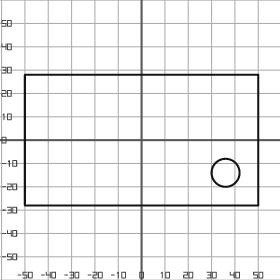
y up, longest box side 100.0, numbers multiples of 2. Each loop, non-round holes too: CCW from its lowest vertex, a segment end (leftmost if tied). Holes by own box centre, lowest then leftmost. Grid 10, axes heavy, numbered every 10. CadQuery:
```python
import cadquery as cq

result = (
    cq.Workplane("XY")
    .moveTo(-50.0, -28.0)
    .lineTo(50.0, -28.0)
    .lineTo(50.0, 28.0)
    .lineTo(-50.0, 28.0)
    .close()
    .moveTo(36.0, -14.0)
    .circle(6.0)
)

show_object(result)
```